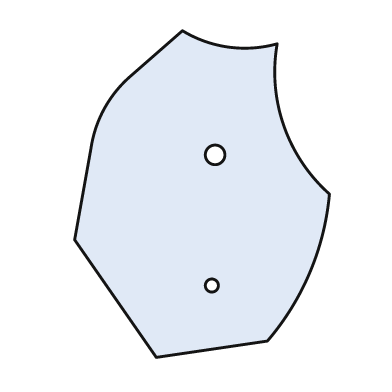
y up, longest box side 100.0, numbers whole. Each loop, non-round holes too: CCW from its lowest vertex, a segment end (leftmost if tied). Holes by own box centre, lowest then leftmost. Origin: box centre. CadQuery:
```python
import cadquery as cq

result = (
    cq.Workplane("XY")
    .moveTo(-14.0, -50.0)
    .lineTo(20.0, -45.0)
    .threePointArc((33.0, -24.0), (39.0, 0.0))
    .threePointArc((25.0, 21.0), (23.0, 46.0))
    .threePointArc((8.0, 45.0), (-6.0, 50.0))
    .lineTo(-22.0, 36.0)
    .threePointArc((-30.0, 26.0), (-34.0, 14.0))
    .lineTo(-39.0, -14.0)
    .close()
    .moveTo(3.0, -28.0)
    .circle(2.0)
    .moveTo(4.0, 12.0)
    .circle(3.0)
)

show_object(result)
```